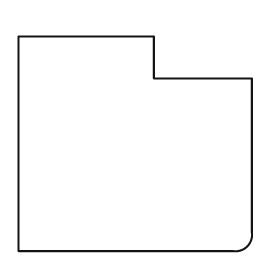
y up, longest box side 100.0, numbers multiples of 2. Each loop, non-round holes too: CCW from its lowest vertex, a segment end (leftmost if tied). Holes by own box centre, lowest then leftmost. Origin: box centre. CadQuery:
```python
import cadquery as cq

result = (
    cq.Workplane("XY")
    .moveTo(-50.0, -46.0)
    .lineTo(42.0, -46.0)
    .threePointArc((48.0, -44.0), (50.0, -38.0))
    .lineTo(50.0, 28.0)
    .lineTo(8.0, 28.0)
    .lineTo(8.0, 46.0)
    .lineTo(-50.0, 46.0)
    .close()
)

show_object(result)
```